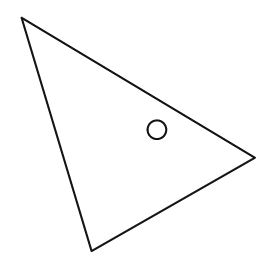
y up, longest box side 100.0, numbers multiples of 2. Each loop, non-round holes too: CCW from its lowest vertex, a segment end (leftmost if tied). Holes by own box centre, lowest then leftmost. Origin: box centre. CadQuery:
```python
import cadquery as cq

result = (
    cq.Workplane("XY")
    .moveTo(-20.0, -50.0)
    .lineTo(50.0, -10.0)
    .lineTo(-50.0, 50.0)
    .close()
    .moveTo(8.0, 2.0)
    .circle(4.0)
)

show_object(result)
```